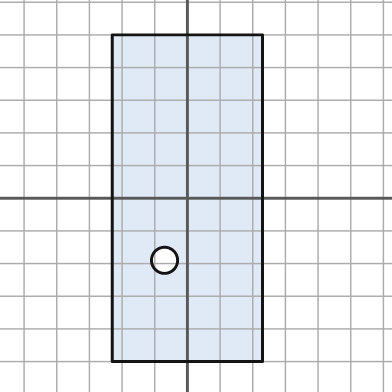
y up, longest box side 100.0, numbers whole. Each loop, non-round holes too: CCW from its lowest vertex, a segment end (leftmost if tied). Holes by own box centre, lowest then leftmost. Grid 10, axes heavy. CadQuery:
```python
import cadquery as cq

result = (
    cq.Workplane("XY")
    .moveTo(-23.0, -50.0)
    .lineTo(23.0, -50.0)
    .lineTo(23.0, 50.0)
    .lineTo(-23.0, 50.0)
    .close()
    .moveTo(-7.0, -19.0)
    .circle(4.0)
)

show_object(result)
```